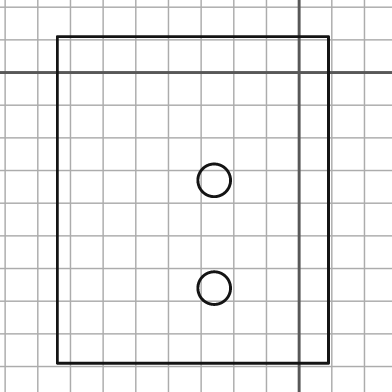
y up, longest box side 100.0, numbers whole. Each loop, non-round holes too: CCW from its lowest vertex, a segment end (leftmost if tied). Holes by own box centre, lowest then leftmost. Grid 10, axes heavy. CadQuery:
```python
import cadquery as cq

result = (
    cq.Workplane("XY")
    .moveTo(-74.0, -89.0)
    .lineTo(9.0, -89.0)
    .lineTo(9.0, 11.0)
    .lineTo(-74.0, 11.0)
    .close()
    .moveTo(-26.0, -66.0)
    .circle(5.0)
    .moveTo(-26.0, -33.0)
    .circle(5.0)
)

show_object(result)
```